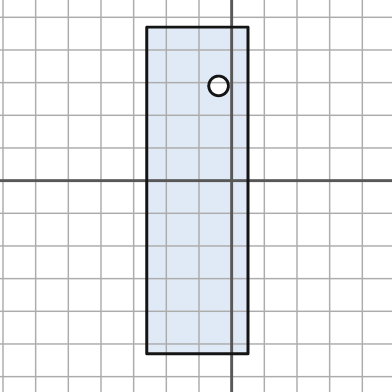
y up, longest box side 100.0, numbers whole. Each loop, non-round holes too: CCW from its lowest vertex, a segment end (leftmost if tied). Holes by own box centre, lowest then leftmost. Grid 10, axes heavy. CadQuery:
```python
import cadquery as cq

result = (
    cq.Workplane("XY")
    .moveTo(-26.0, -53.0)
    .lineTo(5.0, -53.0)
    .lineTo(5.0, 47.0)
    .lineTo(-26.0, 47.0)
    .close()
    .moveTo(-4.0, 29.0)
    .circle(3.0)
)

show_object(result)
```